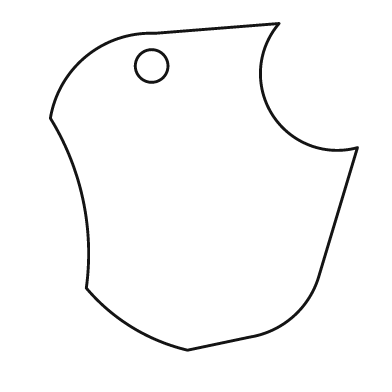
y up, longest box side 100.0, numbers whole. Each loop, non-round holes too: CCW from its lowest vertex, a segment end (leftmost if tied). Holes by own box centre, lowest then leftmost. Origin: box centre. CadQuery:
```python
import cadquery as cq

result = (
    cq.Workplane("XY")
    .moveTo(-5.0, -50.0)
    .lineTo(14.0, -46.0)
    .threePointArc((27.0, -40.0), (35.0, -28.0))
    .lineTo(47.0, 12.0)
    .threePointArc((21.0, 22.0), (23.0, 50.0))
    .lineTo(-15.0, 47.0)
    .threePointArc((-36.0, 40.0), (-47.0, 21.0))
    .threePointArc((-37.0, -4.0), (-36.0, -31.0))
    .threePointArc((-22.0, -43.0), (-5.0, -50.0))
    .close()
    .moveTo(-16.0, 37.0)
    .circle(5.0)
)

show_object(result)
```